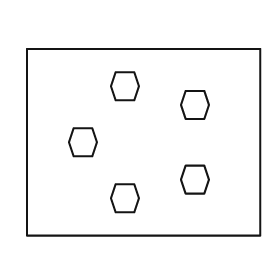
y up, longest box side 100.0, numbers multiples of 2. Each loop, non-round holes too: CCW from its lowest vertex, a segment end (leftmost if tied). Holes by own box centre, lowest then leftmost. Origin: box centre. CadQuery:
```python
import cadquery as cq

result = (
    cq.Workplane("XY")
    .moveTo(-50.0, -40.0)
    .lineTo(50.0, -40.0)
    .lineTo(50.0, 40.0)
    .lineTo(-50.0, 40.0)
    .close()
    .moveTo(-12.0, -30.0)
    .lineTo(-4.0, -30.0)
    .lineTo(-2.0, -24.0)
    .lineTo(-4.0, -18.0)
    .lineTo(-12.0, -18.0)
    .lineTo(-14.0, -24.0)
    .close()
    .moveTo(18.0, -22.0)
    .lineTo(26.0, -22.0)
    .lineTo(28.0, -16.0)
    .lineTo(26.0, -10.0)
    .lineTo(18.0, -10.0)
    .lineTo(16.0, -16.0)
    .close()
    .moveTo(-30.0, -6.0)
    .lineTo(-22.0, -6.0)
    .lineTo(-20.0, 0.0)
    .lineTo(-22.0, 6.0)
    .lineTo(-30.0, 6.0)
    .lineTo(-32.0, 0.0)
    .close()
    .moveTo(18.0, 10.0)
    .lineTo(26.0, 10.0)
    .lineTo(28.0, 16.0)
    .lineTo(26.0, 22.0)
    .lineTo(18.0, 22.0)
    .lineTo(16.0, 16.0)
    .close()
    .moveTo(-12.0, 18.0)
    .lineTo(-4.0, 18.0)
    .lineTo(-2.0, 24.0)
    .lineTo(-4.0, 30.0)
    .lineTo(-12.0, 30.0)
    .lineTo(-14.0, 24.0)
    .close()
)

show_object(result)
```